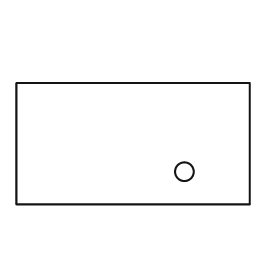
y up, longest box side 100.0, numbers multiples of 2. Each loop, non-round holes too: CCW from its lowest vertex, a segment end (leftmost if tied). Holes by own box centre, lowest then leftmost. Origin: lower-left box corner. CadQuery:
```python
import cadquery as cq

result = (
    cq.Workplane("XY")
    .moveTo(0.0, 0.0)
    .lineTo(100.0, 0.0)
    .lineTo(100.0, 52.0)
    .lineTo(0.0, 52.0)
    .close()
    .moveTo(72.0, 14.0)
    .circle(4.0)
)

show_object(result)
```